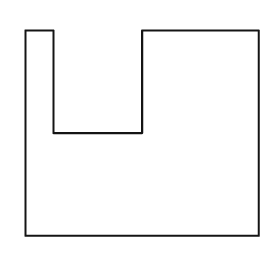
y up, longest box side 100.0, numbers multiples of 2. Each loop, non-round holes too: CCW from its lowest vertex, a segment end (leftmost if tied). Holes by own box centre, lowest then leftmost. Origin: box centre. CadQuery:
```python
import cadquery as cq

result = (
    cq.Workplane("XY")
    .moveTo(-50.0, -44.0)
    .lineTo(50.0, -44.0)
    .lineTo(50.0, 44.0)
    .lineTo(0.0, 44.0)
    .lineTo(0.0, 0.0)
    .lineTo(-38.0, 0.0)
    .lineTo(-38.0, 44.0)
    .lineTo(-50.0, 44.0)
    .close()
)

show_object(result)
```